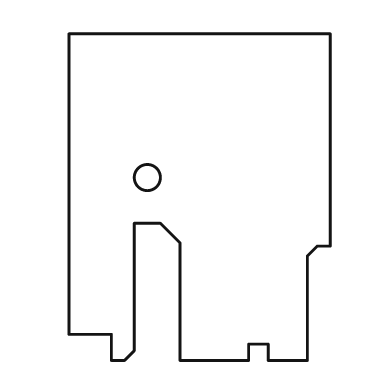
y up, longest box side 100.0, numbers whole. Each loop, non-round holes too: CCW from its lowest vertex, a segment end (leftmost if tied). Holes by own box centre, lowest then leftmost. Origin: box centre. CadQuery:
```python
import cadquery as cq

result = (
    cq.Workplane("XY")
    .moveTo(-27.0, -50.0)
    .lineTo(-23.0, -50.0)
    .lineTo(-20.0, -47.0)
    .lineTo(-20.0, -8.0)
    .lineTo(-12.0, -8.0)
    .lineTo(-6.0, -14.0)
    .lineTo(-6.0, -50.0)
    .lineTo(15.0, -50.0)
    .lineTo(15.0, -45.0)
    .lineTo(21.0, -45.0)
    .lineTo(21.0, -50.0)
    .lineTo(33.0, -50.0)
    .lineTo(33.0, -18.0)
    .lineTo(36.0, -15.0)
    .lineTo(40.0, -15.0)
    .lineTo(40.0, 50.0)
    .lineTo(-40.0, 50.0)
    .lineTo(-40.0, -42.0)
    .lineTo(-27.0, -42.0)
    .close()
    .moveTo(-16.0, 6.0)
    .circle(4.0)
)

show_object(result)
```